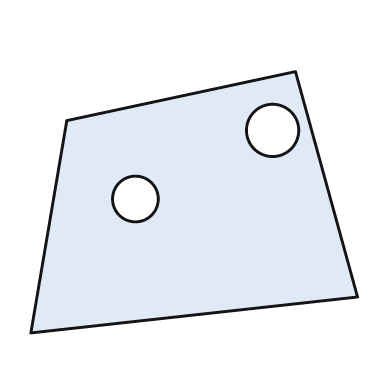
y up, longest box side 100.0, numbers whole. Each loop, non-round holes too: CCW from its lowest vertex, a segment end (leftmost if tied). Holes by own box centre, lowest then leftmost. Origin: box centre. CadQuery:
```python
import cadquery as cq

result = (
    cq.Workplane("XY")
    .moveTo(-50.0, -40.0)
    .lineTo(50.0, -29.0)
    .lineTo(31.0, 40.0)
    .lineTo(-39.0, 25.0)
    .close()
    .moveTo(-18.0, 1.0)
    .circle(7.0)
    .moveTo(24.0, 22.0)
    .circle(8.0)
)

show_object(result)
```